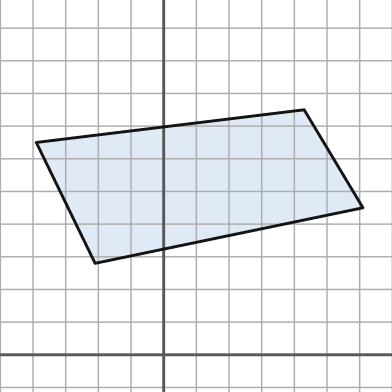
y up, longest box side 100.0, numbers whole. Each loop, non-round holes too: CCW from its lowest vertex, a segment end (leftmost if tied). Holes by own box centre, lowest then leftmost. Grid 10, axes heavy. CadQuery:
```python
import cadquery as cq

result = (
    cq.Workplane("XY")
    .moveTo(-21.0, 28.0)
    .lineTo(61.0, 45.0)
    .lineTo(43.0, 75.0)
    .lineTo(-39.0, 65.0)
    .close()
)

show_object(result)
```